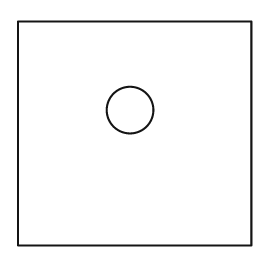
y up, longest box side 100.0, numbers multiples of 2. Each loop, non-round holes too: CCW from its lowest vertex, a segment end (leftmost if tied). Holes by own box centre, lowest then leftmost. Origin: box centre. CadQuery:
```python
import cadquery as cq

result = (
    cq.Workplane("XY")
    .moveTo(-50.0, -48.0)
    .lineTo(50.0, -48.0)
    .lineTo(50.0, 48.0)
    .lineTo(-50.0, 48.0)
    .close()
    .moveTo(-2.0, 10.0)
    .circle(10.0)
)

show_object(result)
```